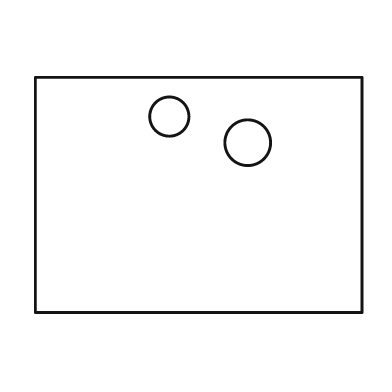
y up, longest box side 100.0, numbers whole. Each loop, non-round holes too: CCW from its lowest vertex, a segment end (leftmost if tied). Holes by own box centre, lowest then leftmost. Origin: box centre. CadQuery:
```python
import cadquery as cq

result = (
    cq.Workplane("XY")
    .moveTo(-50.0, -36.0)
    .lineTo(50.0, -36.0)
    .lineTo(50.0, 36.0)
    .lineTo(-50.0, 36.0)
    .close()
    .moveTo(15.0, 16.0)
    .circle(7.0)
    .moveTo(-9.0, 24.0)
    .circle(6.0)
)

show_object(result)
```